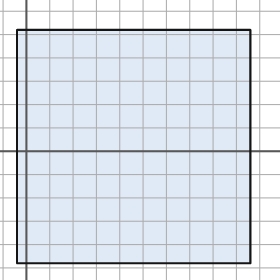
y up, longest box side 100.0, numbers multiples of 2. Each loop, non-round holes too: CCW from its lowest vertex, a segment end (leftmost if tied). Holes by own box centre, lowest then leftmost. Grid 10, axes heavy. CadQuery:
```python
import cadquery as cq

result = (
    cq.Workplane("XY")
    .moveTo(-4.0, -48.0)
    .lineTo(96.0, -48.0)
    .lineTo(96.0, 52.0)
    .lineTo(-4.0, 52.0)
    .close()
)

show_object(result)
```